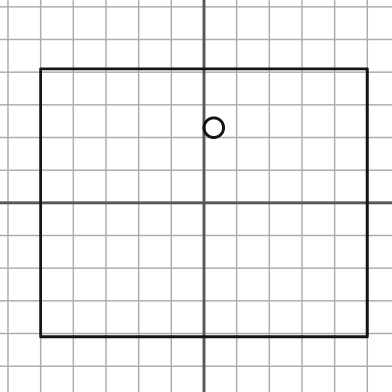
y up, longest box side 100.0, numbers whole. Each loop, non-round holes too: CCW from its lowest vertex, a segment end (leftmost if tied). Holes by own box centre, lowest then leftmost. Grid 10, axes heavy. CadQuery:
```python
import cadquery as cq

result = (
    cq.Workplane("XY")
    .moveTo(-50.0, -41.0)
    .lineTo(50.0, -41.0)
    .lineTo(50.0, 41.0)
    .lineTo(-50.0, 41.0)
    .close()
    .moveTo(3.0, 23.0)
    .circle(3.0)
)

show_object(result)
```